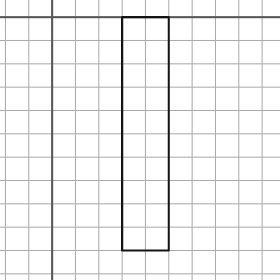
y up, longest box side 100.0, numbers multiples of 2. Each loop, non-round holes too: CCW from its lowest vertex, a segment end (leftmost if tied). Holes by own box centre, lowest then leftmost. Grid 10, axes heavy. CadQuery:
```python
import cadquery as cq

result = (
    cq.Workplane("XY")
    .moveTo(30.0, -100.0)
    .lineTo(50.0, -100.0)
    .lineTo(50.0, 0.0)
    .lineTo(30.0, 0.0)
    .close()
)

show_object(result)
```